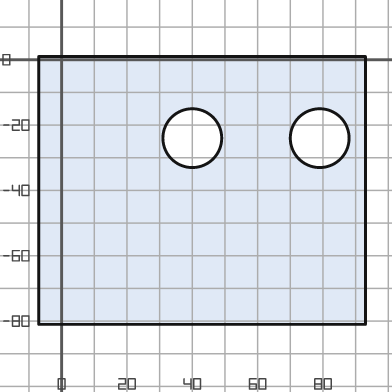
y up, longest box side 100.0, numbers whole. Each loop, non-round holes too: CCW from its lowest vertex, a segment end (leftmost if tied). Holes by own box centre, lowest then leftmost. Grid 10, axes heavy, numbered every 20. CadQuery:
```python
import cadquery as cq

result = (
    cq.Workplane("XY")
    .moveTo(-7.0, -81.0)
    .lineTo(93.0, -81.0)
    .lineTo(93.0, 1.0)
    .lineTo(-7.0, 1.0)
    .close()
    .moveTo(40.0, -24.0)
    .circle(9.0)
    .moveTo(79.0, -24.0)
    .circle(9.0)
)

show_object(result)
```